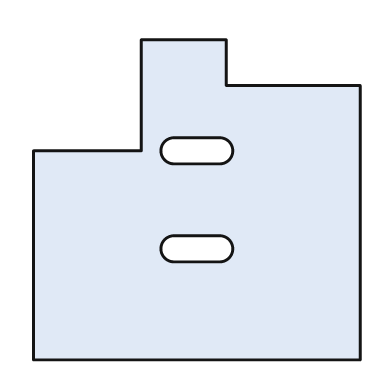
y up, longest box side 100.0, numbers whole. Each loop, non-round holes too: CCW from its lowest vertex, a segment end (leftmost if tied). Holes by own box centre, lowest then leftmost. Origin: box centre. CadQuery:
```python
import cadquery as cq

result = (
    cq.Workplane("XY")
    .moveTo(-50.0, -49.0)
    .lineTo(50.0, -49.0)
    .lineTo(50.0, 35.0)
    .lineTo(9.0, 35.0)
    .lineTo(9.0, 49.0)
    .lineTo(-17.0, 49.0)
    .lineTo(-17.0, 15.0)
    .lineTo(-50.0, 15.0)
    .close()
    .moveTo(-7.0, -19.0)
    .lineTo(7.0, -19.0)
    .threePointArc((11.0, -15.0), (7.0, -11.0))
    .lineTo(-7.0, -11.0)
    .threePointArc((-11.0, -15.0), (-7.0, -19.0))
    .close()
    .moveTo(-7.0, 11.0)
    .lineTo(7.0, 11.0)
    .threePointArc((11.0, 15.0), (7.0, 19.0))
    .lineTo(-7.0, 19.0)
    .threePointArc((-11.0, 15.0), (-7.0, 11.0))
    .close()
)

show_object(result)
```